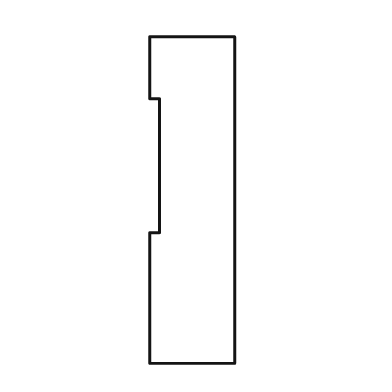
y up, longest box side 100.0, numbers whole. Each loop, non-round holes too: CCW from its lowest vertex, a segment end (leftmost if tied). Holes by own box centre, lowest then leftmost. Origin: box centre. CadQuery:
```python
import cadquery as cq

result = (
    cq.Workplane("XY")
    .moveTo(-13.0, -50.0)
    .lineTo(13.0, -50.0)
    .lineTo(13.0, 50.0)
    .lineTo(-13.0, 50.0)
    .lineTo(-13.0, 31.0)
    .lineTo(-10.0, 31.0)
    .lineTo(-10.0, -10.0)
    .lineTo(-13.0, -10.0)
    .close()
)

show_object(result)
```